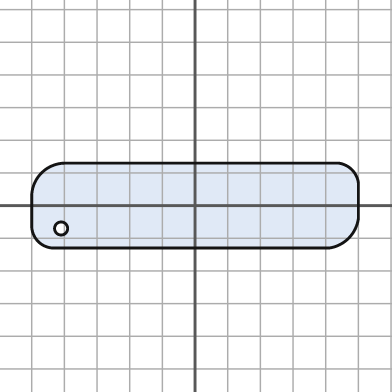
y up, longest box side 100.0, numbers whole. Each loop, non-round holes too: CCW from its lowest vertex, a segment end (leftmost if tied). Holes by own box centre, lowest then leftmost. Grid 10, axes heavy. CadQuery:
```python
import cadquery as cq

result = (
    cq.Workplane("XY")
    .moveTo(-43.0, -13.0)
    .lineTo(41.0, -13.0)
    .threePointArc((47.0, -10.0), (50.0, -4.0))
    .lineTo(50.0, 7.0)
    .threePointArc((48.0, 11.0), (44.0, 13.0))
    .lineTo(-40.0, 13.0)
    .threePointArc((-47.0, 10.0), (-50.0, 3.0))
    .lineTo(-50.0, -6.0)
    .threePointArc((-48.0, -11.0), (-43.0, -13.0))
    .close()
    .moveTo(-41.0, -7.0)
    .circle(2.0)
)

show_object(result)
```